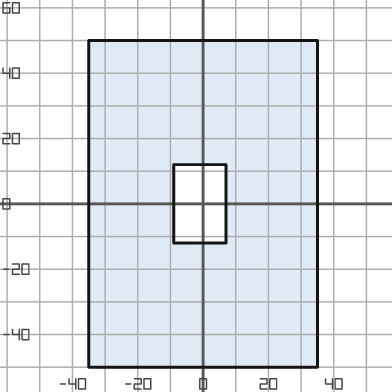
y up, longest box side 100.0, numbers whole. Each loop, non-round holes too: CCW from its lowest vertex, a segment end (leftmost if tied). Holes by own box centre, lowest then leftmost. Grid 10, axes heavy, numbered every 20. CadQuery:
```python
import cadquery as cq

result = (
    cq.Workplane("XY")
    .moveTo(-35.0, -50.0)
    .lineTo(35.0, -50.0)
    .lineTo(35.0, 50.0)
    .lineTo(-35.0, 50.0)
    .close()
    .moveTo(-9.0, -12.0)
    .lineTo(7.0, -12.0)
    .lineTo(7.0, 12.0)
    .lineTo(-9.0, 12.0)
    .close()
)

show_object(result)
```